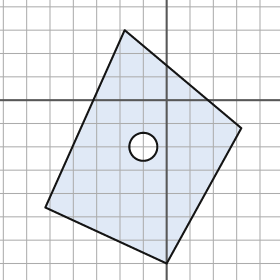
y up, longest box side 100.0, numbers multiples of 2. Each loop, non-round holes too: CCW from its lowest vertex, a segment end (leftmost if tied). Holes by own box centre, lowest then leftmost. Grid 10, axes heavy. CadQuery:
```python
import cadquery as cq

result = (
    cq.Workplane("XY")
    .moveTo(0.0, -70.0)
    .lineTo(32.0, -12.0)
    .lineTo(-18.0, 30.0)
    .lineTo(-52.0, -46.0)
    .close()
    .moveTo(-10.0, -20.0)
    .circle(6.0)
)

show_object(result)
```